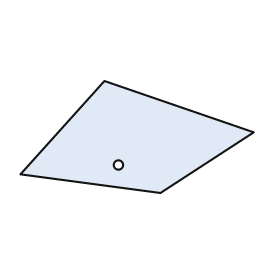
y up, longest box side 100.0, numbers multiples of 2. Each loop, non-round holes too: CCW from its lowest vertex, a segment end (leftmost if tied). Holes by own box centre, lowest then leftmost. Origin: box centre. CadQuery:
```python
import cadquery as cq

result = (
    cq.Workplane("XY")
    .moveTo(10.0, -24.0)
    .lineTo(50.0, 2.0)
    .lineTo(-14.0, 24.0)
    .lineTo(-50.0, -16.0)
    .close()
    .moveTo(-8.0, -12.0)
    .circle(2.0)
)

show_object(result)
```